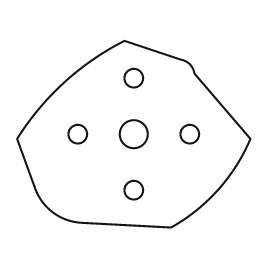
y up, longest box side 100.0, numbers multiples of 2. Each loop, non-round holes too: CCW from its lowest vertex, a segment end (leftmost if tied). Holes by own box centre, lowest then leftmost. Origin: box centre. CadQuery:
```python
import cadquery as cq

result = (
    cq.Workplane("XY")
    .moveTo(16.0, -40.0)
    .threePointArc((36.0, -24.0), (50.0, -2.0))
    .lineTo(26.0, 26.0)
    .threePointArc((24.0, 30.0), (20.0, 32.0))
    .lineTo(-4.0, 40.0)
    .threePointArc((-30.0, 22.0), (-50.0, -2.0))
    .lineTo(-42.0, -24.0)
    .threePointArc((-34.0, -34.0), (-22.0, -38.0))
    .close()
    .moveTo(0.0, -24.0)
    .circle(4.0)
    .moveTo(-24.0, 0.0)
    .circle(4.0)
    .moveTo(0.0, 0.0)
    .circle(6.0)
    .moveTo(24.0, 0.0)
    .circle(4.0)
    .moveTo(0.0, 24.0)
    .circle(4.0)
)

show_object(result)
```